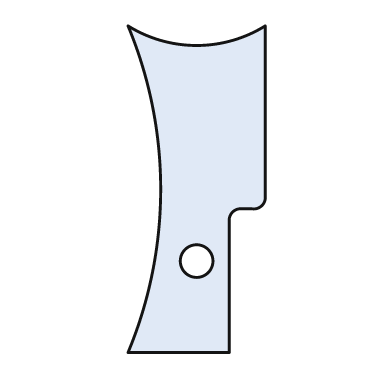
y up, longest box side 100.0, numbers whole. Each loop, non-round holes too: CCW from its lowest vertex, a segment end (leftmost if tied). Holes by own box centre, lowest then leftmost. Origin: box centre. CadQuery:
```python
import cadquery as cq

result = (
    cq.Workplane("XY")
    .moveTo(-21.0, -50.0)
    .lineTo(10.0, -50.0)
    .lineTo(10.0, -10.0)
    .threePointArc((11.0, -7.0), (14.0, -6.0))
    .lineTo(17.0, -6.0)
    .threePointArc((20.0, -5.0), (21.0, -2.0))
    .lineTo(21.0, 50.0)
    .threePointArc((0.0, 44.0), (-21.0, 50.0))
    .threePointArc((-11.0, 0.0), (-21.0, -50.0))
    .close()
    .moveTo(0.0, -22.0)
    .circle(5.0)
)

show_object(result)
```